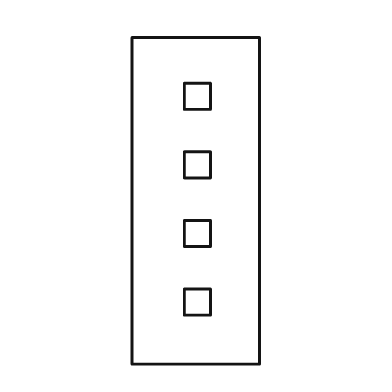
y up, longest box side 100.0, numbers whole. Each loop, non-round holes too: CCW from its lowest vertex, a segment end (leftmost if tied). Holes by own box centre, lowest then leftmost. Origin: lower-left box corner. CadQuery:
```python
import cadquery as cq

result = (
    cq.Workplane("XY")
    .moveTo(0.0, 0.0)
    .lineTo(39.0, 0.0)
    .lineTo(39.0, 100.0)
    .lineTo(0.0, 100.0)
    .close()
    .moveTo(16.0, 15.0)
    .lineTo(24.0, 15.0)
    .lineTo(24.0, 23.0)
    .lineTo(16.0, 23.0)
    .close()
    .moveTo(16.0, 36.0)
    .lineTo(24.0, 36.0)
    .lineTo(24.0, 44.0)
    .lineTo(16.0, 44.0)
    .close()
    .moveTo(16.0, 57.0)
    .lineTo(24.0, 57.0)
    .lineTo(24.0, 65.0)
    .lineTo(16.0, 65.0)
    .close()
    .moveTo(16.0, 78.0)
    .lineTo(24.0, 78.0)
    .lineTo(24.0, 86.0)
    .lineTo(16.0, 86.0)
    .close()
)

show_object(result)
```